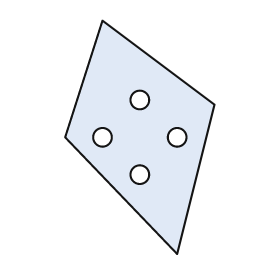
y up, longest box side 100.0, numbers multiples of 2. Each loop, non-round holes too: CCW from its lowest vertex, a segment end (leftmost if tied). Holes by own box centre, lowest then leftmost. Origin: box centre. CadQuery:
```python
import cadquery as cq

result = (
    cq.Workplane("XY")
    .moveTo(16.0, -50.0)
    .lineTo(32.0, 14.0)
    .lineTo(-16.0, 50.0)
    .lineTo(-32.0, 0.0)
    .close()
    .moveTo(0.0, -16.0)
    .circle(4.0)
    .moveTo(-16.0, 0.0)
    .circle(4.0)
    .moveTo(16.0, 0.0)
    .circle(4.0)
    .moveTo(0.0, 16.0)
    .circle(4.0)
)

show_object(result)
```